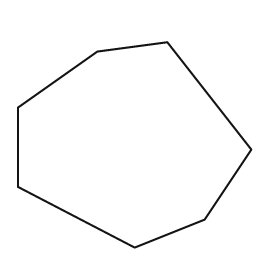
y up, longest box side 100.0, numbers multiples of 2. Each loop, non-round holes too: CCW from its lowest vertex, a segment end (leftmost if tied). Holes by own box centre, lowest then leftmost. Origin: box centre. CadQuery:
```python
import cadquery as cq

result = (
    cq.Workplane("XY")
    .moveTo(0.0, -44.0)
    .lineTo(30.0, -32.0)
    .lineTo(50.0, -2.0)
    .lineTo(14.0, 44.0)
    .lineTo(-16.0, 40.0)
    .lineTo(-50.0, 16.0)
    .lineTo(-50.0, -18.0)
    .close()
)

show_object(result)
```